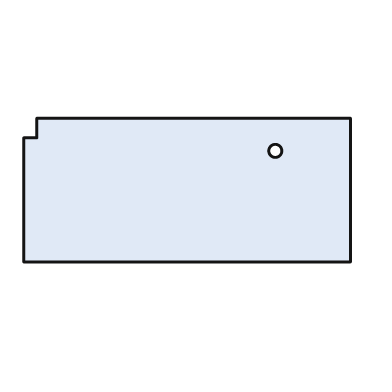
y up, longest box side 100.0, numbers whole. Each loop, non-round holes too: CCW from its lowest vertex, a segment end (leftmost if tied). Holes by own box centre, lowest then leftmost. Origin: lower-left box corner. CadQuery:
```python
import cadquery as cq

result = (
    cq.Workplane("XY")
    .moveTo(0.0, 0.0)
    .lineTo(100.0, 0.0)
    .lineTo(100.0, 44.0)
    .lineTo(4.0, 44.0)
    .lineTo(4.0, 38.0)
    .lineTo(0.0, 38.0)
    .close()
    .moveTo(77.0, 34.0)
    .circle(2.0)
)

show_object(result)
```